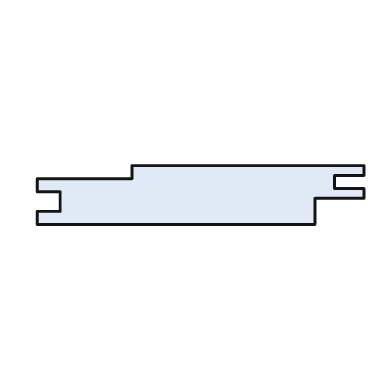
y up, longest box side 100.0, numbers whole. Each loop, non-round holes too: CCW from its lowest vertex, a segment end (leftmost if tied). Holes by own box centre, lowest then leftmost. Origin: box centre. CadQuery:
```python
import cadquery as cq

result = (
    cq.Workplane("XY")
    .moveTo(-50.0, -9.0)
    .lineTo(35.0, -9.0)
    .lineTo(35.0, -1.0)
    .lineTo(50.0, -1.0)
    .lineTo(50.0, 2.0)
    .lineTo(41.0, 2.0)
    .lineTo(41.0, 6.0)
    .lineTo(50.0, 6.0)
    .lineTo(50.0, 9.0)
    .lineTo(-21.0, 9.0)
    .lineTo(-21.0, 5.0)
    .lineTo(-50.0, 5.0)
    .lineTo(-50.0, 1.0)
    .lineTo(-43.0, 1.0)
    .lineTo(-43.0, -5.0)
    .lineTo(-50.0, -5.0)
    .close()
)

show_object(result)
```